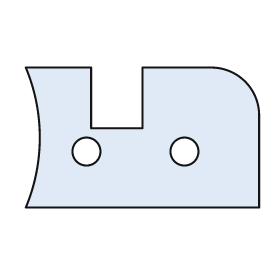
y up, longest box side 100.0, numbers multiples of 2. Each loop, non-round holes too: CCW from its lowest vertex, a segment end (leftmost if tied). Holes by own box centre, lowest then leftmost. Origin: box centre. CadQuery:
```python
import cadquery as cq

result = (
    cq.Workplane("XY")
    .moveTo(-50.0, -30.0)
    .lineTo(50.0, -30.0)
    .lineTo(50.0, 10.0)
    .threePointArc((44.0, 24.0), (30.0, 30.0))
    .lineTo(0.0, 30.0)
    .lineTo(0.0, 4.0)
    .lineTo(-22.0, 4.0)
    .lineTo(-22.0, 30.0)
    .lineTo(-50.0, 30.0)
    .threePointArc((-44.0, 0.0), (-50.0, -30.0))
    .close()
    .moveTo(-24.0, -6.0)
    .circle(6.0)
    .moveTo(18.0, -6.0)
    .circle(6.0)
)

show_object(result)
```